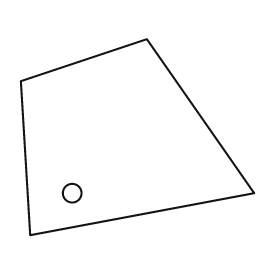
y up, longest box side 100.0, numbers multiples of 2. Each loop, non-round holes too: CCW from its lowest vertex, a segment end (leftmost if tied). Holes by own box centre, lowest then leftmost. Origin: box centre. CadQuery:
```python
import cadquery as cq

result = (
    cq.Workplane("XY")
    .moveTo(-46.0, -42.0)
    .lineTo(50.0, -24.0)
    .lineTo(4.0, 42.0)
    .lineTo(-50.0, 24.0)
    .close()
    .moveTo(-28.0, -24.0)
    .circle(4.0)
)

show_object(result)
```